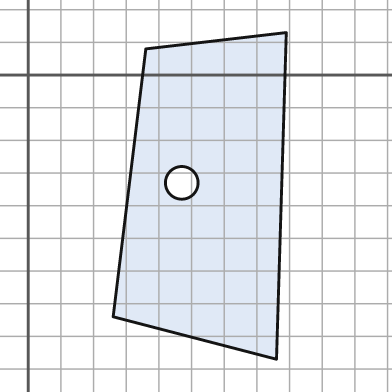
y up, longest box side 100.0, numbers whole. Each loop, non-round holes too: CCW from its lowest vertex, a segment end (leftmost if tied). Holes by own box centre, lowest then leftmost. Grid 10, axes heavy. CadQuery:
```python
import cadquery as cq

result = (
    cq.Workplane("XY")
    .moveTo(76.0, -87.0)
    .lineTo(79.0, 13.0)
    .lineTo(36.0, 8.0)
    .lineTo(26.0, -74.0)
    .close()
    .moveTo(47.0, -33.0)
    .circle(5.0)
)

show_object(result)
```